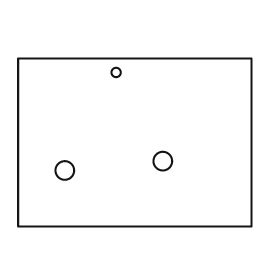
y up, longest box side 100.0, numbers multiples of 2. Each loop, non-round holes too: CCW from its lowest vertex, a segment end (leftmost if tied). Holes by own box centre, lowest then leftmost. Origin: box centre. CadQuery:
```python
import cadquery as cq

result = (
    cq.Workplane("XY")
    .moveTo(-50.0, -36.0)
    .lineTo(50.0, -36.0)
    .lineTo(50.0, 36.0)
    .lineTo(-50.0, 36.0)
    .close()
    .moveTo(-30.0, -12.0)
    .circle(4.0)
    .moveTo(12.0, -8.0)
    .circle(4.0)
    .moveTo(-8.0, 30.0)
    .circle(2.0)
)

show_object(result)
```